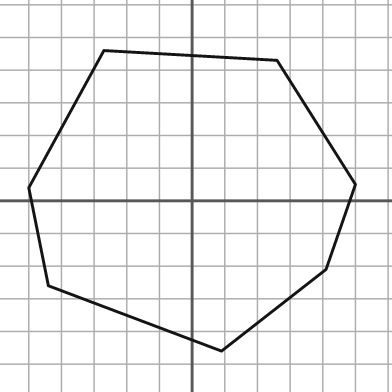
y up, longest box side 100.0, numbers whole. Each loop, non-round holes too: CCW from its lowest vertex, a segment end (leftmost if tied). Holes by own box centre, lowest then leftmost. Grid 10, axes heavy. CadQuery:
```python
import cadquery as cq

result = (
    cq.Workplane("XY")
    .moveTo(9.0, -46.0)
    .lineTo(41.0, -21.0)
    .lineTo(50.0, 5.0)
    .lineTo(26.0, 43.0)
    .lineTo(-27.0, 46.0)
    .lineTo(-50.0, 4.0)
    .lineTo(-44.0, -26.0)
    .close()
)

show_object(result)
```